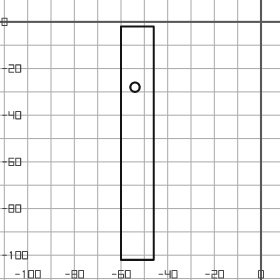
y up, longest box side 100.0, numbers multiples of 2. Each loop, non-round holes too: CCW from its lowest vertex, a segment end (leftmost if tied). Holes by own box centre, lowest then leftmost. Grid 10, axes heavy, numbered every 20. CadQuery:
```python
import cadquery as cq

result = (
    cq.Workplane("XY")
    .moveTo(-60.0, -102.0)
    .lineTo(-46.0, -102.0)
    .lineTo(-46.0, -2.0)
    .lineTo(-60.0, -2.0)
    .close()
    .moveTo(-54.0, -28.0)
    .circle(2.0)
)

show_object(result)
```